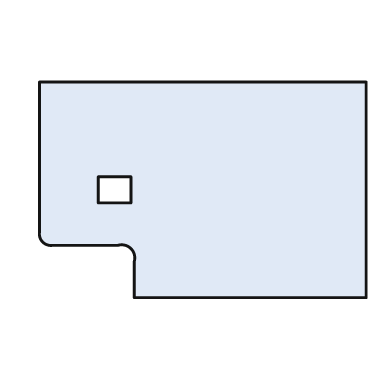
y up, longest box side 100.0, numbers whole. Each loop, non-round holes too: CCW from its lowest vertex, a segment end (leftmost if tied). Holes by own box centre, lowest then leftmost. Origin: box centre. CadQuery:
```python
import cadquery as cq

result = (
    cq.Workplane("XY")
    .moveTo(-21.0, -33.0)
    .lineTo(50.0, -33.0)
    .lineTo(50.0, 33.0)
    .lineTo(-50.0, 33.0)
    .lineTo(-50.0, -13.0)
    .threePointArc((-49.0, -16.0), (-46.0, -17.0))
    .lineTo(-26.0, -17.0)
    .threePointArc((-22.0, -18.0), (-21.0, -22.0))
    .close()
    .moveTo(-32.0, -4.0)
    .lineTo(-22.0, -4.0)
    .lineTo(-22.0, 4.0)
    .lineTo(-32.0, 4.0)
    .close()
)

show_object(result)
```